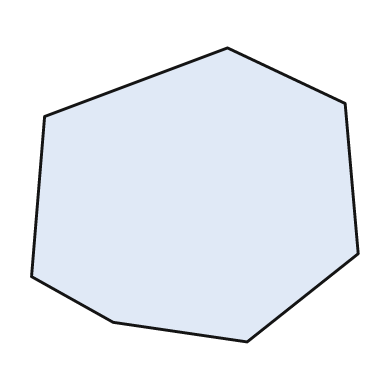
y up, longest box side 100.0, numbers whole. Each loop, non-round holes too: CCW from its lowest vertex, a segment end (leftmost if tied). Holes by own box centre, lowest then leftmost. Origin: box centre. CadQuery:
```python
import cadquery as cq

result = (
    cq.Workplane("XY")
    .moveTo(16.0, -45.0)
    .lineTo(50.0, -18.0)
    .lineTo(46.0, 28.0)
    .lineTo(10.0, 45.0)
    .lineTo(-46.0, 24.0)
    .lineTo(-50.0, -25.0)
    .lineTo(-25.0, -39.0)
    .close()
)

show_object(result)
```